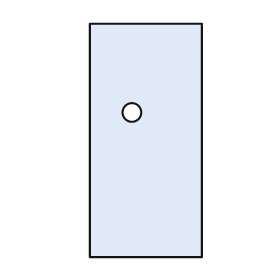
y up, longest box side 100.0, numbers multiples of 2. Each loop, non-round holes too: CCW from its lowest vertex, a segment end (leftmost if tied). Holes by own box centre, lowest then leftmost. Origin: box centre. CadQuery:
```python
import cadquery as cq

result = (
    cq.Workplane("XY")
    .moveTo(-24.0, -50.0)
    .lineTo(24.0, -50.0)
    .lineTo(24.0, 50.0)
    .lineTo(-24.0, 50.0)
    .close()
    .moveTo(-6.0, 12.0)
    .circle(4.0)
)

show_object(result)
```